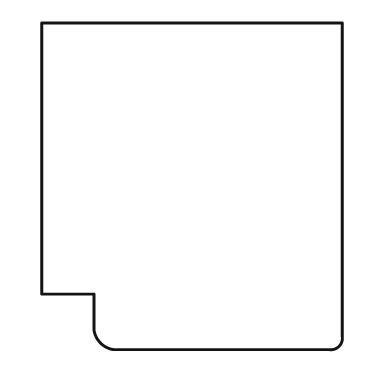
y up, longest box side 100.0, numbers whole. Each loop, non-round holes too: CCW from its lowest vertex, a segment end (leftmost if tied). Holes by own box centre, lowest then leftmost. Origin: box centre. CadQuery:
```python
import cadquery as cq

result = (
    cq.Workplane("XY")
    .moveTo(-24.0, -50.0)
    .lineTo(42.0, -50.0)
    .threePointArc((45.0, -49.0), (46.0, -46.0))
    .lineTo(46.0, 50.0)
    .lineTo(-46.0, 50.0)
    .lineTo(-46.0, -33.0)
    .lineTo(-30.0, -33.0)
    .lineTo(-30.0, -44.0)
    .threePointArc((-28.0, -48.0), (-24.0, -50.0))
    .close()
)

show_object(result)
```